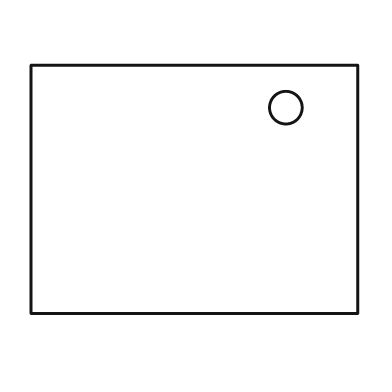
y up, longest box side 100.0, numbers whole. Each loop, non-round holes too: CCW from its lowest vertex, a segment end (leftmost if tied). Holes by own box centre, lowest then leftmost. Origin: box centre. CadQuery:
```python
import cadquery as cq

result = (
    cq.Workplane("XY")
    .moveTo(-50.0, -38.0)
    .lineTo(50.0, -38.0)
    .lineTo(50.0, 38.0)
    .lineTo(-50.0, 38.0)
    .close()
    .moveTo(28.0, 25.0)
    .circle(5.0)
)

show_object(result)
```